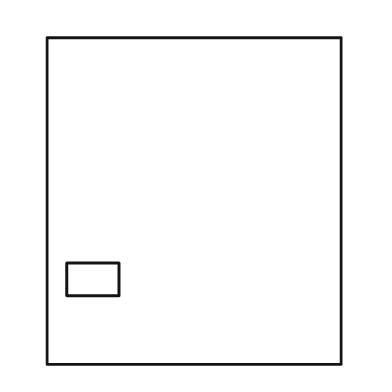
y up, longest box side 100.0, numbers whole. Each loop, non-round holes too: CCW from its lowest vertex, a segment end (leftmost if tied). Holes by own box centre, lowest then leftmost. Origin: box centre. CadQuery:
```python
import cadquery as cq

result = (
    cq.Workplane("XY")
    .moveTo(-45.0, -50.0)
    .lineTo(45.0, -50.0)
    .lineTo(45.0, 50.0)
    .lineTo(-45.0, 50.0)
    .close()
    .moveTo(-39.0, -29.0)
    .lineTo(-23.0, -29.0)
    .lineTo(-23.0, -19.0)
    .lineTo(-39.0, -19.0)
    .close()
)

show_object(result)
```